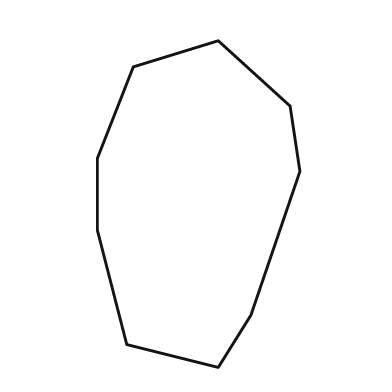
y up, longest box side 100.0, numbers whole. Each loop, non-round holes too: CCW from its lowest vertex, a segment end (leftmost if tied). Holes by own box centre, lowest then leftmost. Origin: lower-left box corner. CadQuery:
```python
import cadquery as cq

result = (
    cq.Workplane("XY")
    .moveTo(37.0, 0.0)
    .lineTo(47.0, 16.0)
    .lineTo(62.0, 60.0)
    .lineTo(59.0, 80.0)
    .lineTo(37.0, 100.0)
    .lineTo(11.0, 92.0)
    .lineTo(0.0, 64.0)
    .lineTo(0.0, 42.0)
    .lineTo(9.0, 7.0)
    .close()
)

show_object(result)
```